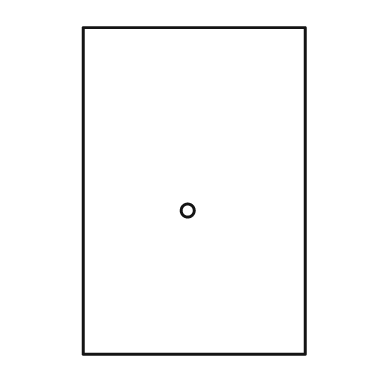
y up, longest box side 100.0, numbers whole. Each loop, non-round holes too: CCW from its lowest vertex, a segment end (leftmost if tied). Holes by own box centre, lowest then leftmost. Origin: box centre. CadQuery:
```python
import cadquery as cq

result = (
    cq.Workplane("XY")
    .moveTo(-34.0, -50.0)
    .lineTo(34.0, -50.0)
    .lineTo(34.0, 50.0)
    .lineTo(-34.0, 50.0)
    .close()
    .moveTo(-2.0, -6.0)
    .circle(2.0)
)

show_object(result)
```